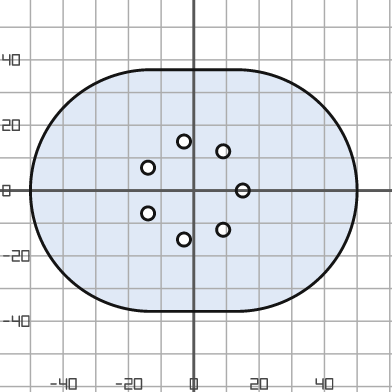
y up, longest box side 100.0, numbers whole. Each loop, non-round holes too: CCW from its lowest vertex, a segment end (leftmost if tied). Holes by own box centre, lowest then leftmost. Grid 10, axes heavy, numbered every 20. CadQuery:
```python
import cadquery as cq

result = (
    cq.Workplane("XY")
    .moveTo(-13.0, -37.0)
    .lineTo(13.0, -37.0)
    .threePointArc((50.0, 0.0), (13.0, 37.0))
    .lineTo(-13.0, 37.0)
    .threePointArc((-50.0, 0.0), (-13.0, -37.0))
    .close()
    .moveTo(-3.0, -15.0)
    .circle(2.0)
    .moveTo(9.0, -12.0)
    .circle(2.0)
    .moveTo(-14.0, -7.0)
    .circle(2.0)
    .moveTo(15.0, 0.0)
    .circle(2.0)
    .moveTo(-14.0, 7.0)
    .circle(2.0)
    .moveTo(9.0, 12.0)
    .circle(2.0)
    .moveTo(-3.0, 15.0)
    .circle(2.0)
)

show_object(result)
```